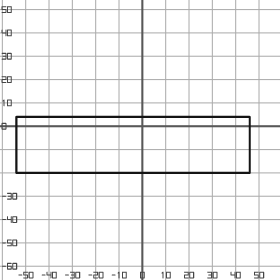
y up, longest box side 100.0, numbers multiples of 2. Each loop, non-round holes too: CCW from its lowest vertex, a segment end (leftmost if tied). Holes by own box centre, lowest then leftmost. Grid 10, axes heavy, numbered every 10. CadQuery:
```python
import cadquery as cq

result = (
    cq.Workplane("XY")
    .moveTo(-54.0, -20.0)
    .lineTo(46.0, -20.0)
    .lineTo(46.0, 4.0)
    .lineTo(-54.0, 4.0)
    .close()
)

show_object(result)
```